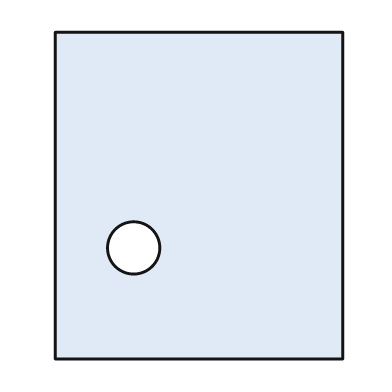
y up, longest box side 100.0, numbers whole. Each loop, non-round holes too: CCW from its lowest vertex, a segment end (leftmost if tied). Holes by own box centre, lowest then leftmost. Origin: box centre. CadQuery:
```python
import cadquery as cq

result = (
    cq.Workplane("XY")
    .moveTo(-44.0, -50.0)
    .lineTo(44.0, -50.0)
    .lineTo(44.0, 50.0)
    .lineTo(-44.0, 50.0)
    .close()
    .moveTo(-20.0, -16.0)
    .circle(8.0)
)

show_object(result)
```